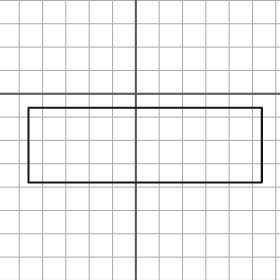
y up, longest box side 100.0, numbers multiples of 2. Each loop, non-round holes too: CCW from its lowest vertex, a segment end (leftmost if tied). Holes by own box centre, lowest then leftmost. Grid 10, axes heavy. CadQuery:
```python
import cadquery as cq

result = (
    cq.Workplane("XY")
    .moveTo(-46.0, -38.0)
    .lineTo(54.0, -38.0)
    .lineTo(54.0, -6.0)
    .lineTo(-46.0, -6.0)
    .close()
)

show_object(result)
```